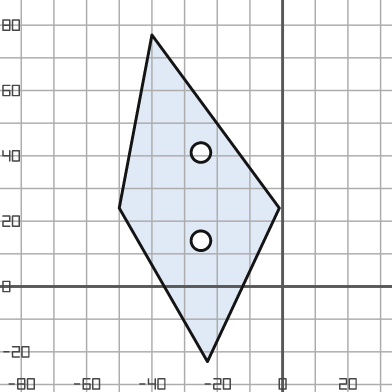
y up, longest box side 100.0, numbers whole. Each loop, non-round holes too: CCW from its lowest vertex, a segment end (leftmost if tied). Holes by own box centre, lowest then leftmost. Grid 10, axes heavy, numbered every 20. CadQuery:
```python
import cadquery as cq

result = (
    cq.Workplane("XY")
    .moveTo(-23.0, -23.0)
    .lineTo(-1.0, 24.0)
    .lineTo(-40.0, 77.0)
    .lineTo(-50.0, 24.0)
    .close()
    .moveTo(-25.0, 14.0)
    .circle(3.0)
    .moveTo(-25.0, 41.0)
    .circle(3.0)
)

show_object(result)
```